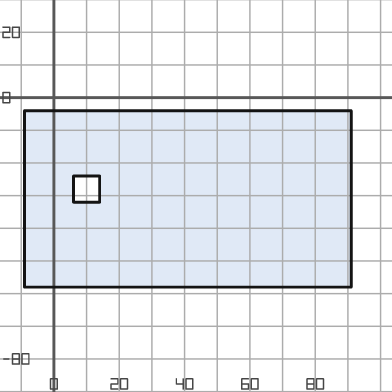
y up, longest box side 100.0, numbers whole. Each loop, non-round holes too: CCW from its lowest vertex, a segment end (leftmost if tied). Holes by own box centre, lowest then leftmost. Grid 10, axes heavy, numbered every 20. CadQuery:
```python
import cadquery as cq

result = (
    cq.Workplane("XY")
    .moveTo(-9.0, -58.0)
    .lineTo(91.0, -58.0)
    .lineTo(91.0, -4.0)
    .lineTo(-9.0, -4.0)
    .close()
    .moveTo(6.0, -32.0)
    .lineTo(14.0, -32.0)
    .lineTo(14.0, -24.0)
    .lineTo(6.0, -24.0)
    .close()
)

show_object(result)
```